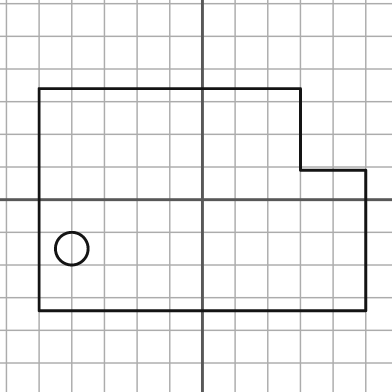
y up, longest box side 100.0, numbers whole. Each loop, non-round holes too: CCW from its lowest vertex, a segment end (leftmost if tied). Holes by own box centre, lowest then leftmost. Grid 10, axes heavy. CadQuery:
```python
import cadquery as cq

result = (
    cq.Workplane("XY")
    .moveTo(-50.0, -34.0)
    .lineTo(50.0, -34.0)
    .lineTo(50.0, 9.0)
    .lineTo(30.0, 9.0)
    .lineTo(30.0, 34.0)
    .lineTo(-50.0, 34.0)
    .close()
    .moveTo(-40.0, -15.0)
    .circle(5.0)
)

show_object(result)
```